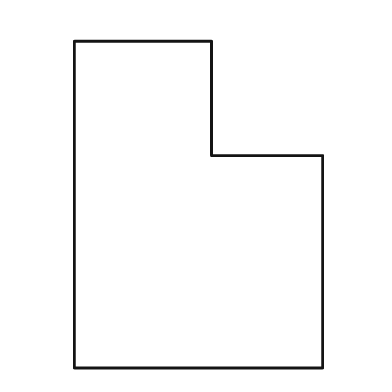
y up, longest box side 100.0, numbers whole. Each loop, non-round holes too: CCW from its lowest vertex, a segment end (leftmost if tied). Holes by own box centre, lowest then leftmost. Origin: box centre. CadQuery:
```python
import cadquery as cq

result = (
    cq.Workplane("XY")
    .moveTo(-38.0, -50.0)
    .lineTo(38.0, -50.0)
    .lineTo(38.0, 15.0)
    .lineTo(4.0, 15.0)
    .lineTo(4.0, 50.0)
    .lineTo(-38.0, 50.0)
    .close()
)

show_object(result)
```